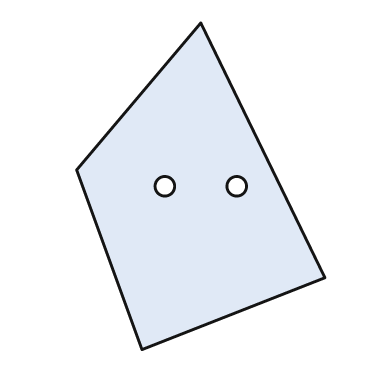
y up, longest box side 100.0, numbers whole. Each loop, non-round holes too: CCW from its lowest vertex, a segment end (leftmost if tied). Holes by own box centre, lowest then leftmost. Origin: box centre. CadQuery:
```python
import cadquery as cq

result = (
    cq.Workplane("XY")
    .moveTo(-18.0, -50.0)
    .lineTo(38.0, -28.0)
    .lineTo(0.0, 50.0)
    .lineTo(-38.0, 5.0)
    .close()
    .moveTo(-11.0, 0.0)
    .circle(3.0)
    .moveTo(11.0, 0.0)
    .circle(3.0)
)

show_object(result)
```